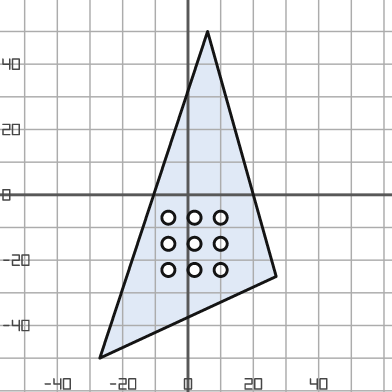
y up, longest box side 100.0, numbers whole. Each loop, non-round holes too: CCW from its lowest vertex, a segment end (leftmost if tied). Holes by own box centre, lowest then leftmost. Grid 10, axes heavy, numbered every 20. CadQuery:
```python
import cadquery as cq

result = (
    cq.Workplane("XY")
    .moveTo(-27.0, -50.0)
    .lineTo(27.0, -25.0)
    .lineTo(6.0, 50.0)
    .close()
    .moveTo(-6.0, -23.0)
    .circle(2.0)
    .moveTo(2.0, -23.0)
    .circle(2.0)
    .moveTo(10.0, -23.0)
    .circle(2.0)
    .moveTo(-6.0, -15.0)
    .circle(2.0)
    .moveTo(2.0, -15.0)
    .circle(2.0)
    .moveTo(10.0, -15.0)
    .circle(2.0)
    .moveTo(-6.0, -7.0)
    .circle(2.0)
    .moveTo(2.0, -7.0)
    .circle(2.0)
    .moveTo(10.0, -7.0)
    .circle(2.0)
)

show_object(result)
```